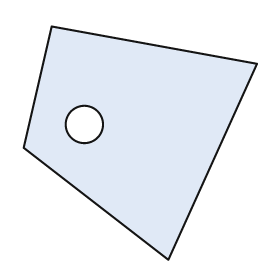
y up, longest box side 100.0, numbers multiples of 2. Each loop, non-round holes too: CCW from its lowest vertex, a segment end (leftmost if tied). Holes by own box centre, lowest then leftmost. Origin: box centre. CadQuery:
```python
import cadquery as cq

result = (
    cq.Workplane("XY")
    .moveTo(12.0, -50.0)
    .lineTo(50.0, 34.0)
    .lineTo(-38.0, 50.0)
    .lineTo(-50.0, -2.0)
    .close()
    .moveTo(-24.0, 8.0)
    .circle(8.0)
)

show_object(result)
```